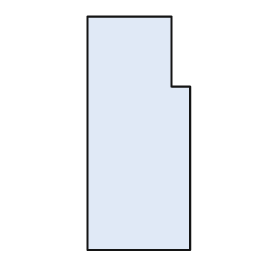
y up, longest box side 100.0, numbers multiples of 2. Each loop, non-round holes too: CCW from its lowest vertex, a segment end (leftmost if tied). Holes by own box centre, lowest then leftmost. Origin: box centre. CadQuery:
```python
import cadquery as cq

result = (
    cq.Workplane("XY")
    .moveTo(-22.0, -50.0)
    .lineTo(22.0, -50.0)
    .lineTo(22.0, 20.0)
    .lineTo(14.0, 20.0)
    .lineTo(14.0, 50.0)
    .lineTo(-22.0, 50.0)
    .close()
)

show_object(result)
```